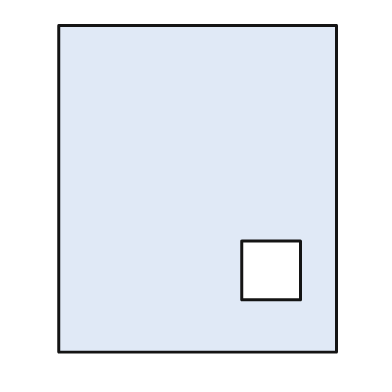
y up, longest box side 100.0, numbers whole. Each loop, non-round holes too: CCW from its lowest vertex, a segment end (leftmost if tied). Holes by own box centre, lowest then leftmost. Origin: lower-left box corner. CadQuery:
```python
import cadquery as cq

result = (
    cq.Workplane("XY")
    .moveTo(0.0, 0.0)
    .lineTo(85.0, 0.0)
    .lineTo(85.0, 100.0)
    .lineTo(0.0, 100.0)
    .close()
    .moveTo(56.0, 16.0)
    .lineTo(74.0, 16.0)
    .lineTo(74.0, 34.0)
    .lineTo(56.0, 34.0)
    .close()
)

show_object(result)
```